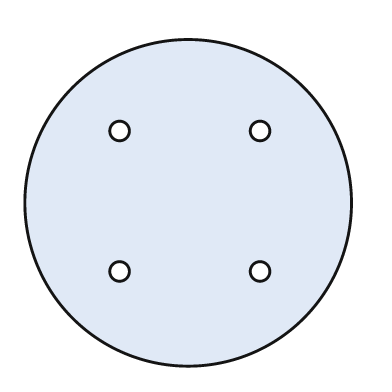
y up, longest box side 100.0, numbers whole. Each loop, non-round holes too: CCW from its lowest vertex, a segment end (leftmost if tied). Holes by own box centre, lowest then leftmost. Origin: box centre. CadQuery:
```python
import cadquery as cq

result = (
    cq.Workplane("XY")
    .moveTo(0.0, 0.0)
    .circle(50.0)
    .moveTo(-21.0, -21.0)
    .circle(3.0)
    .moveTo(22.0, -21.0)
    .circle(3.0)
    .moveTo(-21.0, 22.0)
    .circle(3.0)
    .moveTo(22.0, 22.0)
    .circle(3.0)
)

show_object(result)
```